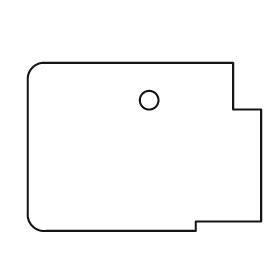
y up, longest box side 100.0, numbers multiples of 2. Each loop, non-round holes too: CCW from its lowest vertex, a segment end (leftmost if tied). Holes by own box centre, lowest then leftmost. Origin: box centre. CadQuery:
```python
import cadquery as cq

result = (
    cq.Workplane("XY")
    .moveTo(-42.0, -36.0)
    .lineTo(22.0, -36.0)
    .lineTo(22.0, -32.0)
    .lineTo(50.0, -32.0)
    .lineTo(50.0, 16.0)
    .lineTo(38.0, 16.0)
    .lineTo(38.0, 36.0)
    .lineTo(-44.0, 36.0)
    .threePointArc((-48.0, 34.0), (-50.0, 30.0))
    .lineTo(-50.0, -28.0)
    .threePointArc((-48.0, -34.0), (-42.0, -36.0))
    .close()
    .moveTo(2.0, 20.0)
    .circle(4.0)
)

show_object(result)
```